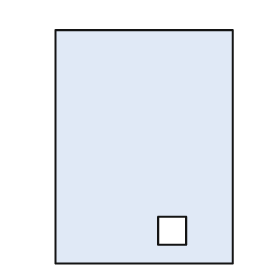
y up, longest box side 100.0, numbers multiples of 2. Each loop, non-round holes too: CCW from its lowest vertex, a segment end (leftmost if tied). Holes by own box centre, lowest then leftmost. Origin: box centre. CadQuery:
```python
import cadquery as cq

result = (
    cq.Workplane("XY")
    .moveTo(-38.0, -50.0)
    .lineTo(38.0, -50.0)
    .lineTo(38.0, 50.0)
    .lineTo(-38.0, 50.0)
    .close()
    .moveTo(6.0, -42.0)
    .lineTo(18.0, -42.0)
    .lineTo(18.0, -30.0)
    .lineTo(6.0, -30.0)
    .close()
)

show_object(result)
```